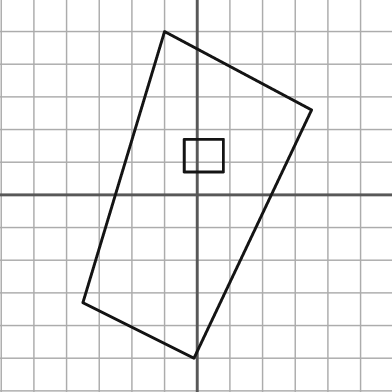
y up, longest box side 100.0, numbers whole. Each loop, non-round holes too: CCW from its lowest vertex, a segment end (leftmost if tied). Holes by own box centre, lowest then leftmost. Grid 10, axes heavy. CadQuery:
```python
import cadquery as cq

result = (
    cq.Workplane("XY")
    .moveTo(-1.0, -50.0)
    .lineTo(35.0, 26.0)
    .lineTo(-10.0, 50.0)
    .lineTo(-35.0, -33.0)
    .close()
    .moveTo(-4.0, 7.0)
    .lineTo(8.0, 7.0)
    .lineTo(8.0, 17.0)
    .lineTo(-4.0, 17.0)
    .close()
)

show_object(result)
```